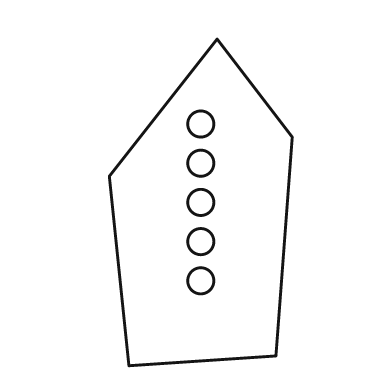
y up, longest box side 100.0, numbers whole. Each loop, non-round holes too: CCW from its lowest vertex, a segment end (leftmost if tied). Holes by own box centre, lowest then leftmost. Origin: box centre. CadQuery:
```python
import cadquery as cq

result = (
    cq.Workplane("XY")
    .moveTo(-22.0, -50.0)
    .lineTo(23.0, -47.0)
    .lineTo(28.0, 20.0)
    .lineTo(5.0, 50.0)
    .lineTo(-28.0, 8.0)
    .close()
    .moveTo(0.0, -24.0)
    .circle(4.0)
    .moveTo(0.0, -12.0)
    .circle(4.0)
    .moveTo(0.0, 0.0)
    .circle(4.0)
    .moveTo(0.0, 12.0)
    .circle(4.0)
    .moveTo(0.0, 24.0)
    .circle(4.0)
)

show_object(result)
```